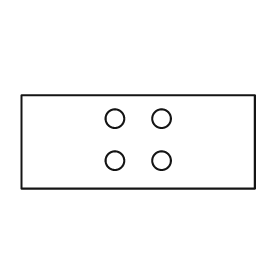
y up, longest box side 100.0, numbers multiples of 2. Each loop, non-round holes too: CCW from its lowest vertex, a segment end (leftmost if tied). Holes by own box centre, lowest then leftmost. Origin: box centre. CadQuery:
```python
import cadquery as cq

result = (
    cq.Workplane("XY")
    .moveTo(-50.0, -20.0)
    .lineTo(50.0, -20.0)
    .lineTo(50.0, 20.0)
    .lineTo(-50.0, 20.0)
    .close()
    .moveTo(-10.0, -8.0)
    .circle(4.0)
    .moveTo(10.0, -8.0)
    .circle(4.0)
    .moveTo(-10.0, 10.0)
    .circle(4.0)
    .moveTo(10.0, 10.0)
    .circle(4.0)
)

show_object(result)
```